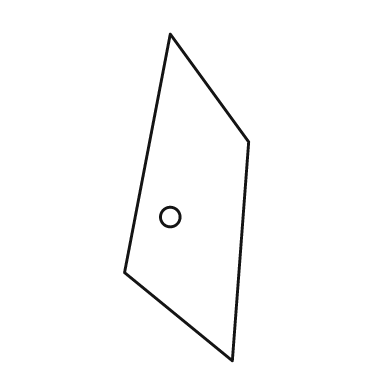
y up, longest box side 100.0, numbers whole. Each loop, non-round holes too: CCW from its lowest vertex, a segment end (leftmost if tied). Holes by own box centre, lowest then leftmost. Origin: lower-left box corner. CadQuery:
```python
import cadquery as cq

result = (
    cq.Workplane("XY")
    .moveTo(33.0, 0.0)
    .lineTo(38.0, 67.0)
    .lineTo(14.0, 100.0)
    .lineTo(0.0, 27.0)
    .close()
    .moveTo(14.0, 44.0)
    .circle(3.0)
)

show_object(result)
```